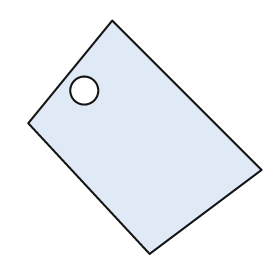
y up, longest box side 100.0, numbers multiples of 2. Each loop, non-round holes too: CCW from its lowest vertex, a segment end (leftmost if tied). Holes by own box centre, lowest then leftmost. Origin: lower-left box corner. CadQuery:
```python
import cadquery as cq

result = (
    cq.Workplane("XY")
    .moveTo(52.0, 0.0)
    .lineTo(100.0, 36.0)
    .lineTo(36.0, 100.0)
    .lineTo(0.0, 56.0)
    .close()
    .moveTo(24.0, 70.0)
    .circle(6.0)
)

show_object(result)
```